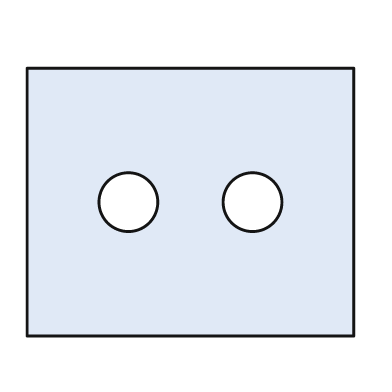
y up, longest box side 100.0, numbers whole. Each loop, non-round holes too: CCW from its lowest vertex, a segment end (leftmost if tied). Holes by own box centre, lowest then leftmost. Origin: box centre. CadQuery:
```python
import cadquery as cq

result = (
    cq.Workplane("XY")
    .moveTo(-50.0, -41.0)
    .lineTo(50.0, -41.0)
    .lineTo(50.0, 41.0)
    .lineTo(-50.0, 41.0)
    .close()
    .moveTo(-19.0, 0.0)
    .circle(9.0)
    .moveTo(19.0, 0.0)
    .circle(9.0)
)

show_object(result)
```